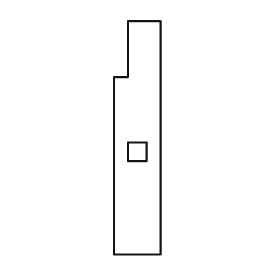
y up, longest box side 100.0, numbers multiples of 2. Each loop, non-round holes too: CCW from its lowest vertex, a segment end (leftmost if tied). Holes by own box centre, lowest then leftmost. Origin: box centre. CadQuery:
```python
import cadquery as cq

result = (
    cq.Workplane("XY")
    .moveTo(-10.0, -50.0)
    .lineTo(10.0, -50.0)
    .lineTo(10.0, 50.0)
    .lineTo(-4.0, 50.0)
    .lineTo(-4.0, 26.0)
    .lineTo(-10.0, 26.0)
    .close()
    .moveTo(-4.0, -10.0)
    .lineTo(4.0, -10.0)
    .lineTo(4.0, -2.0)
    .lineTo(-4.0, -2.0)
    .close()
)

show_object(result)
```